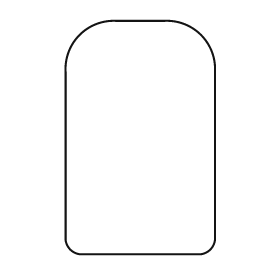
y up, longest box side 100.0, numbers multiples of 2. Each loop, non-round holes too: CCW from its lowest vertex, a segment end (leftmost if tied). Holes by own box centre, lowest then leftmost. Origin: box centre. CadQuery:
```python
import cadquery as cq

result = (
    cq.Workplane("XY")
    .moveTo(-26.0, -50.0)
    .lineTo(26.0, -50.0)
    .threePointArc((30.0, -48.0), (32.0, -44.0))
    .lineTo(32.0, 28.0)
    .threePointArc((26.0, 44.0), (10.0, 50.0))
    .lineTo(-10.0, 50.0)
    .threePointArc((-26.0, 44.0), (-32.0, 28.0))
    .lineTo(-32.0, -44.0)
    .threePointArc((-30.0, -48.0), (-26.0, -50.0))
    .close()
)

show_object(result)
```